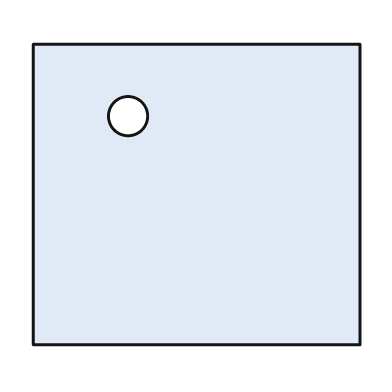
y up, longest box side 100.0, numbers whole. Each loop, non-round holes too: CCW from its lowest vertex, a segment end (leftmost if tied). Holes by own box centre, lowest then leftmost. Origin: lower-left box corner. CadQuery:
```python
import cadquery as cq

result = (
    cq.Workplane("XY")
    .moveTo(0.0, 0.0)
    .lineTo(100.0, 0.0)
    .lineTo(100.0, 92.0)
    .lineTo(0.0, 92.0)
    .close()
    .moveTo(29.0, 70.0)
    .circle(6.0)
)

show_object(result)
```